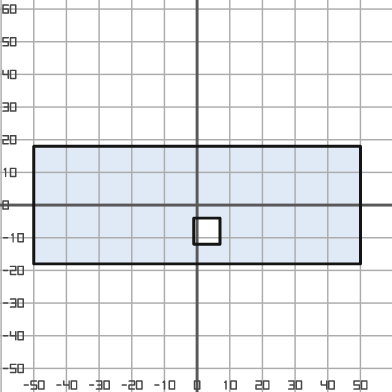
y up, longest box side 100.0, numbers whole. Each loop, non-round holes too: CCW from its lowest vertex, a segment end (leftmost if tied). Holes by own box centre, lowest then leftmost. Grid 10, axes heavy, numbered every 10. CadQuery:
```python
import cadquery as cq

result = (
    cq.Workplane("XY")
    .moveTo(-50.0, -18.0)
    .lineTo(50.0, -18.0)
    .lineTo(50.0, 18.0)
    .lineTo(-50.0, 18.0)
    .close()
    .moveTo(-1.0, -12.0)
    .lineTo(7.0, -12.0)
    .lineTo(7.0, -4.0)
    .lineTo(-1.0, -4.0)
    .close()
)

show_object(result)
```